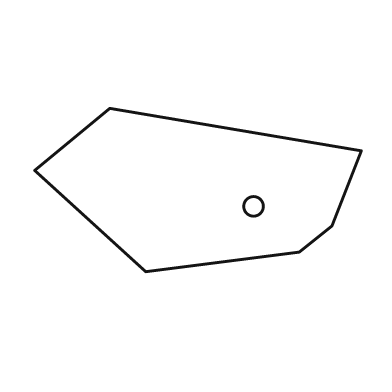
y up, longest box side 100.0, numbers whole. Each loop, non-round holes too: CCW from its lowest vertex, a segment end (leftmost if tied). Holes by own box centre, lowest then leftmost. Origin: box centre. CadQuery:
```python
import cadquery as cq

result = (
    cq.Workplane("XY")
    .moveTo(-16.0, -25.0)
    .lineTo(31.0, -19.0)
    .lineTo(41.0, -11.0)
    .lineTo(50.0, 12.0)
    .lineTo(-27.0, 25.0)
    .lineTo(-50.0, 6.0)
    .close()
    .moveTo(17.0, -5.0)
    .circle(3.0)
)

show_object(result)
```